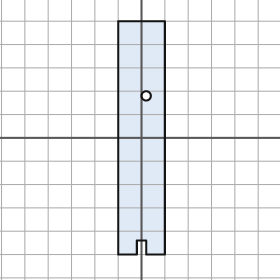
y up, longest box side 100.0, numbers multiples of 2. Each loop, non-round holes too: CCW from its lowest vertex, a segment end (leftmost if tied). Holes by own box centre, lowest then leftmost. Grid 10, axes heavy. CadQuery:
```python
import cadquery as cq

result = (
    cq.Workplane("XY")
    .moveTo(-10.0, -50.0)
    .lineTo(-2.0, -50.0)
    .lineTo(-2.0, -44.0)
    .lineTo(2.0, -44.0)
    .lineTo(2.0, -50.0)
    .lineTo(10.0, -50.0)
    .lineTo(10.0, 50.0)
    .lineTo(-10.0, 50.0)
    .close()
    .moveTo(2.0, 18.0)
    .circle(2.0)
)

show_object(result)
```